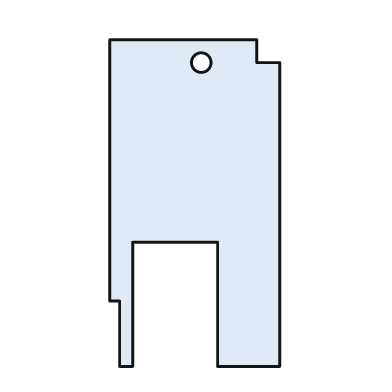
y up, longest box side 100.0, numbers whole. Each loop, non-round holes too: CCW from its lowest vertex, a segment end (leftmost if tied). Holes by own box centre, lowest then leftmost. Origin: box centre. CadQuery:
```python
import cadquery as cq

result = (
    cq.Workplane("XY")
    .moveTo(-23.0, -50.0)
    .lineTo(-19.0, -50.0)
    .lineTo(-19.0, -12.0)
    .lineTo(7.0, -12.0)
    .lineTo(7.0, -50.0)
    .lineTo(26.0, -50.0)
    .lineTo(26.0, 43.0)
    .lineTo(19.0, 43.0)
    .lineTo(19.0, 50.0)
    .lineTo(-26.0, 50.0)
    .lineTo(-26.0, -30.0)
    .lineTo(-23.0, -30.0)
    .close()
    .moveTo(2.0, 43.0)
    .circle(3.0)
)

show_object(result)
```